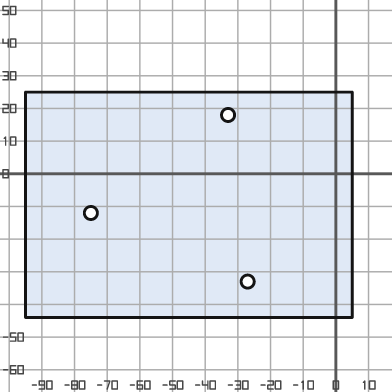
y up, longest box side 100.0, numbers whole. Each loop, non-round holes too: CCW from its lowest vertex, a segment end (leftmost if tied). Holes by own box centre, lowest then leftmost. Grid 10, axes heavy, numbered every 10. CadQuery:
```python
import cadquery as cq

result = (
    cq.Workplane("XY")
    .moveTo(-95.0, -44.0)
    .lineTo(5.0, -44.0)
    .lineTo(5.0, 25.0)
    .lineTo(-95.0, 25.0)
    .close()
    .moveTo(-27.0, -33.0)
    .circle(2.0)
    .moveTo(-75.0, -12.0)
    .circle(2.0)
    .moveTo(-33.0, 18.0)
    .circle(2.0)
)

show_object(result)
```